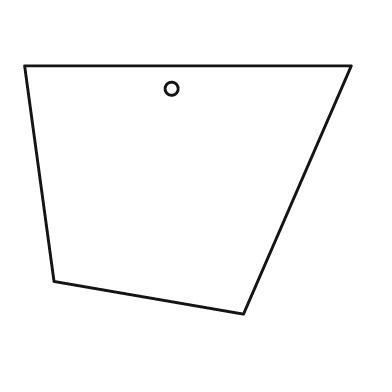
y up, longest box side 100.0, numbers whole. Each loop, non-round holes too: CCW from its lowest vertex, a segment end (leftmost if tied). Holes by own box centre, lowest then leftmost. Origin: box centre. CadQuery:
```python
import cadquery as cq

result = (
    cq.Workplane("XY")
    .moveTo(17.0, -38.0)
    .lineTo(50.0, 38.0)
    .lineTo(-50.0, 38.0)
    .lineTo(-41.0, -28.0)
    .close()
    .moveTo(-5.0, 31.0)
    .circle(2.0)
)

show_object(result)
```